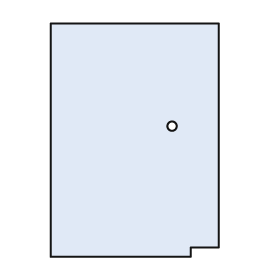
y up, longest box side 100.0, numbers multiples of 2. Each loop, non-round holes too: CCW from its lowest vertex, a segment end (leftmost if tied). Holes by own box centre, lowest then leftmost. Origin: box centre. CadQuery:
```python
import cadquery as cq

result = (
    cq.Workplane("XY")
    .moveTo(-36.0, -50.0)
    .lineTo(24.0, -50.0)
    .lineTo(24.0, -46.0)
    .lineTo(36.0, -46.0)
    .lineTo(36.0, 50.0)
    .lineTo(-36.0, 50.0)
    .close()
    .moveTo(16.0, 6.0)
    .circle(2.0)
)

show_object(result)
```